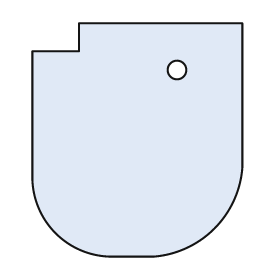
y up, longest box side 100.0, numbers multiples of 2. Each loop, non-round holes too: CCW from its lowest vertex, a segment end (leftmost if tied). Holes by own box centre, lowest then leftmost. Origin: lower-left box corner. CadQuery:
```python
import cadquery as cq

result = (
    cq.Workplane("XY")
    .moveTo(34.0, 0.0)
    .lineTo(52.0, 0.0)
    .threePointArc((78.0, 12.0), (90.0, 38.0))
    .lineTo(90.0, 100.0)
    .lineTo(20.0, 100.0)
    .lineTo(20.0, 88.0)
    .lineTo(0.0, 88.0)
    .lineTo(0.0, 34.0)
    .threePointArc((10.0, 10.0), (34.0, 0.0))
    .close()
    .moveTo(62.0, 80.0)
    .circle(4.0)
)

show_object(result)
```